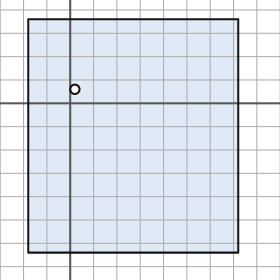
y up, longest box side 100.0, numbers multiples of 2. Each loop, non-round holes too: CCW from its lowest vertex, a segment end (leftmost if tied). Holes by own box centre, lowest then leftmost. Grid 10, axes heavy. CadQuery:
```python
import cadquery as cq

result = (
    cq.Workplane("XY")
    .moveTo(-18.0, -64.0)
    .lineTo(72.0, -64.0)
    .lineTo(72.0, 36.0)
    .lineTo(-18.0, 36.0)
    .close()
    .moveTo(2.0, 6.0)
    .circle(2.0)
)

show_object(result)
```